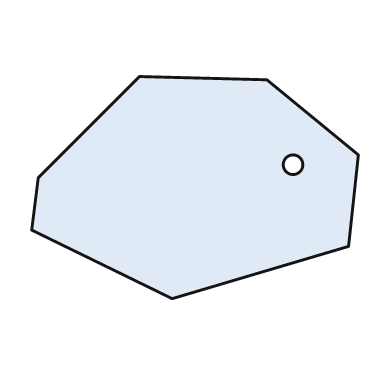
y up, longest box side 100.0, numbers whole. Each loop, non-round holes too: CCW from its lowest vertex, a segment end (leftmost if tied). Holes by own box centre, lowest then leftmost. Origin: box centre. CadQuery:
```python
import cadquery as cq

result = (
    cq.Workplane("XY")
    .moveTo(-7.0, -34.0)
    .lineTo(47.0, -18.0)
    .lineTo(50.0, 10.0)
    .lineTo(22.0, 33.0)
    .lineTo(-17.0, 34.0)
    .lineTo(-48.0, 3.0)
    .lineTo(-50.0, -13.0)
    .close()
    .moveTo(30.0, 7.0)
    .circle(3.0)
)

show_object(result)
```